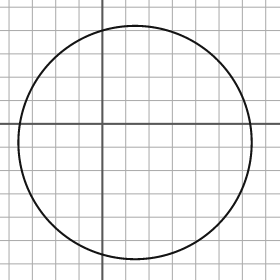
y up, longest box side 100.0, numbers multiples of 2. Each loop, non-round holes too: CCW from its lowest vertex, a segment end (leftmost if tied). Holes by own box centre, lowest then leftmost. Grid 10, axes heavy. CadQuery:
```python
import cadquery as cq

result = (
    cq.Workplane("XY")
    .moveTo(14.0, -8.0)
    .circle(50.0)
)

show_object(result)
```